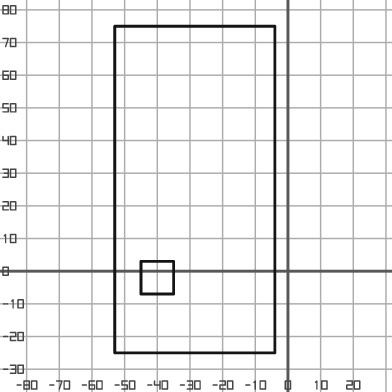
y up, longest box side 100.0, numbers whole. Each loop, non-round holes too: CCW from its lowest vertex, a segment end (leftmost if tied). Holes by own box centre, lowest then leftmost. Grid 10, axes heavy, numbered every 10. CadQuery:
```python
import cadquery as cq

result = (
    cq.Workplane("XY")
    .moveTo(-53.0, -25.0)
    .lineTo(-4.0, -25.0)
    .lineTo(-4.0, 75.0)
    .lineTo(-53.0, 75.0)
    .close()
    .moveTo(-45.0, -7.0)
    .lineTo(-35.0, -7.0)
    .lineTo(-35.0, 3.0)
    .lineTo(-45.0, 3.0)
    .close()
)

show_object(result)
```